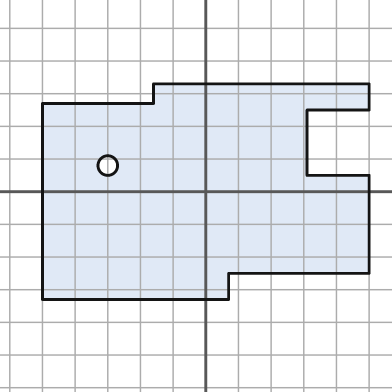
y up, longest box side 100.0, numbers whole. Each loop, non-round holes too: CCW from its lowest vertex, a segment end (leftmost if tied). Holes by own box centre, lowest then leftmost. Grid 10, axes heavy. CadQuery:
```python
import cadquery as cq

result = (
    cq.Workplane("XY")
    .moveTo(-50.0, -33.0)
    .lineTo(7.0, -33.0)
    .lineTo(7.0, -25.0)
    .lineTo(50.0, -25.0)
    .lineTo(50.0, 5.0)
    .lineTo(31.0, 5.0)
    .lineTo(31.0, 25.0)
    .lineTo(50.0, 25.0)
    .lineTo(50.0, 33.0)
    .lineTo(-16.0, 33.0)
    .lineTo(-16.0, 27.0)
    .lineTo(-50.0, 27.0)
    .close()
    .moveTo(-30.0, 8.0)
    .circle(3.0)
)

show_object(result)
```